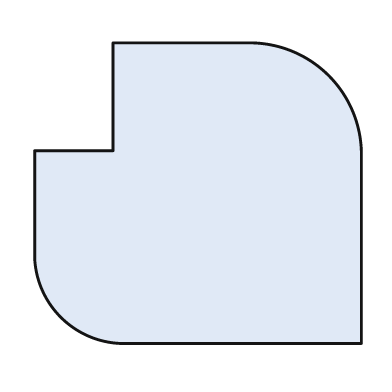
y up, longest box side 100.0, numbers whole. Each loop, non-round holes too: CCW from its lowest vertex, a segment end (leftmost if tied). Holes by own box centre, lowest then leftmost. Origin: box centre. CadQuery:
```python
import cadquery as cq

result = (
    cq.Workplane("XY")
    .moveTo(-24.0, -46.0)
    .lineTo(50.0, -46.0)
    .lineTo(50.0, 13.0)
    .threePointArc((40.0, 36.0), (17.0, 46.0))
    .lineTo(-26.0, 46.0)
    .lineTo(-26.0, 13.0)
    .lineTo(-50.0, 13.0)
    .lineTo(-50.0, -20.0)
    .threePointArc((-42.0, -38.0), (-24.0, -46.0))
    .close()
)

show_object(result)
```